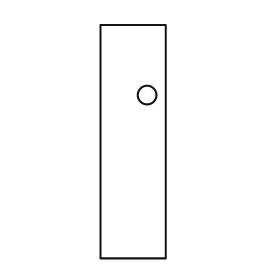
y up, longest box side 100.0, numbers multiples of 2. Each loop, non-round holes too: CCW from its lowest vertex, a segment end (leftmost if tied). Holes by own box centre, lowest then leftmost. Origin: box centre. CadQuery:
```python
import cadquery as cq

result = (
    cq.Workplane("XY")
    .moveTo(-14.0, -50.0)
    .lineTo(14.0, -50.0)
    .lineTo(14.0, 50.0)
    .lineTo(-14.0, 50.0)
    .close()
    .moveTo(6.0, 20.0)
    .circle(4.0)
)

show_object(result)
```